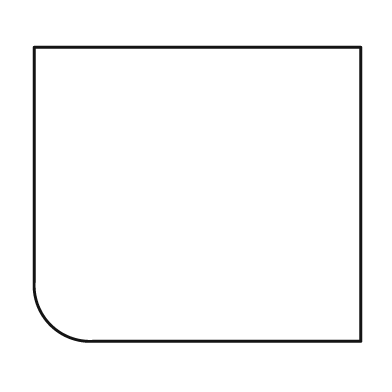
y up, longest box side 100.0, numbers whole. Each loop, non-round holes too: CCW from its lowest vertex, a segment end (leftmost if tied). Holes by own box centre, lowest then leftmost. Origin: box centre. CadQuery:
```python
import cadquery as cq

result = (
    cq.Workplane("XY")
    .moveTo(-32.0, -45.0)
    .lineTo(50.0, -45.0)
    .lineTo(50.0, 45.0)
    .lineTo(-50.0, 45.0)
    .lineTo(-50.0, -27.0)
    .threePointArc((-45.0, -40.0), (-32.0, -45.0))
    .close()
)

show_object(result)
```